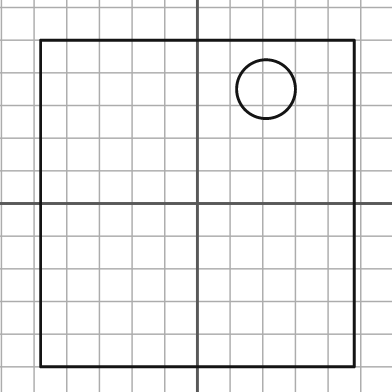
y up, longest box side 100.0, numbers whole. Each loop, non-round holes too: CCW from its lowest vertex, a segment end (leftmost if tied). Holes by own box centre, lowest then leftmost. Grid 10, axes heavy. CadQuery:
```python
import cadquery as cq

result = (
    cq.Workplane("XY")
    .moveTo(-48.0, -50.0)
    .lineTo(48.0, -50.0)
    .lineTo(48.0, 50.0)
    .lineTo(-48.0, 50.0)
    .close()
    .moveTo(21.0, 35.0)
    .circle(9.0)
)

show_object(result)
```